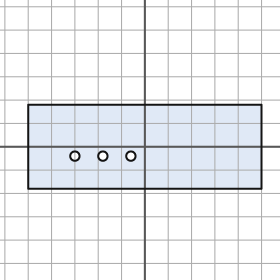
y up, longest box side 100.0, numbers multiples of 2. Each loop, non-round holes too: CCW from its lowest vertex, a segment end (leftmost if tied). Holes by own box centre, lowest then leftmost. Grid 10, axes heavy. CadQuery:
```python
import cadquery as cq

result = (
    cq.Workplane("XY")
    .moveTo(-50.0, -18.0)
    .lineTo(50.0, -18.0)
    .lineTo(50.0, 18.0)
    .lineTo(-50.0, 18.0)
    .close()
    .moveTo(-30.0, -4.0)
    .circle(2.0)
    .moveTo(-18.0, -4.0)
    .circle(2.0)
    .moveTo(-6.0, -4.0)
    .circle(2.0)
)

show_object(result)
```